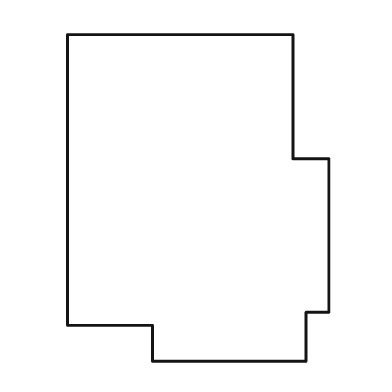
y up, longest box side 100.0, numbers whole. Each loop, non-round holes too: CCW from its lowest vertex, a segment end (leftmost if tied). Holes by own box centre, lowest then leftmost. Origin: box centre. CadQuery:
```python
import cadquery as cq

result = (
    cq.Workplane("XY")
    .moveTo(-14.0, -50.0)
    .lineTo(33.0, -50.0)
    .lineTo(33.0, -35.0)
    .lineTo(40.0, -35.0)
    .lineTo(40.0, 12.0)
    .lineTo(29.0, 12.0)
    .lineTo(29.0, 50.0)
    .lineTo(-40.0, 50.0)
    .lineTo(-40.0, -39.0)
    .lineTo(-14.0, -39.0)
    .close()
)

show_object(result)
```